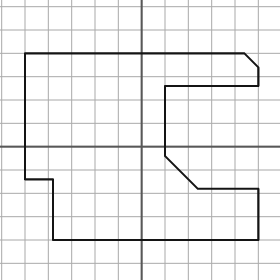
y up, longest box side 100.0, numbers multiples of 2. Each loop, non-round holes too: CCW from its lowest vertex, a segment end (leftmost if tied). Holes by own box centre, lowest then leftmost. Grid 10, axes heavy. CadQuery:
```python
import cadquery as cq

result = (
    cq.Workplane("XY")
    .moveTo(-38.0, -40.0)
    .lineTo(50.0, -40.0)
    .lineTo(50.0, -18.0)
    .lineTo(24.0, -18.0)
    .lineTo(10.0, -4.0)
    .lineTo(10.0, 26.0)
    .lineTo(50.0, 26.0)
    .lineTo(50.0, 34.0)
    .lineTo(44.0, 40.0)
    .lineTo(-50.0, 40.0)
    .lineTo(-50.0, -14.0)
    .lineTo(-38.0, -14.0)
    .close()
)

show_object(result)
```